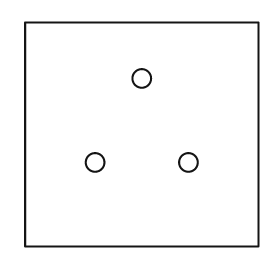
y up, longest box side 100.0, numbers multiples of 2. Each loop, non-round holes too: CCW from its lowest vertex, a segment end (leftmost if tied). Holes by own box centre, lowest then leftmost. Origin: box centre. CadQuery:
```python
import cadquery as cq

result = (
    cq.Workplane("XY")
    .moveTo(-50.0, -48.0)
    .lineTo(50.0, -48.0)
    .lineTo(50.0, 48.0)
    .lineTo(-50.0, 48.0)
    .close()
    .moveTo(-20.0, -12.0)
    .circle(4.0)
    .moveTo(20.0, -12.0)
    .circle(4.0)
    .moveTo(0.0, 24.0)
    .circle(4.0)
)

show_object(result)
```